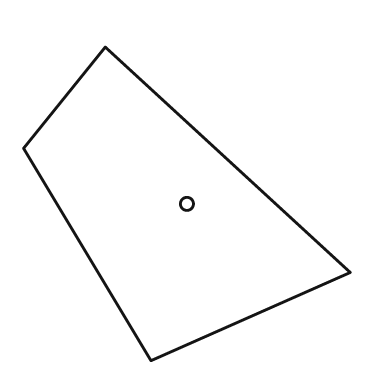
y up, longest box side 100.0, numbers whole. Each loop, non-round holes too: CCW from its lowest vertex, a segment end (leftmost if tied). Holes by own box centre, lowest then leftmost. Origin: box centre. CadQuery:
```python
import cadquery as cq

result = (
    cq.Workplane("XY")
    .moveTo(-11.0, -48.0)
    .lineTo(50.0, -21.0)
    .lineTo(-25.0, 48.0)
    .lineTo(-50.0, 17.0)
    .close()
    .moveTo(0.0, 0.0)
    .circle(2.0)
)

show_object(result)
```